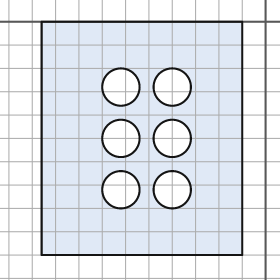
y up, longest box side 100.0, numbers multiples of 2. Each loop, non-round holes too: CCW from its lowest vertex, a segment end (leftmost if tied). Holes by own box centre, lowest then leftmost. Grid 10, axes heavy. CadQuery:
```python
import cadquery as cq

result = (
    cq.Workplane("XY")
    .moveTo(-96.0, -100.0)
    .lineTo(-10.0, -100.0)
    .lineTo(-10.0, 0.0)
    .lineTo(-96.0, 0.0)
    .close()
    .moveTo(-62.0, -72.0)
    .circle(8.0)
    .moveTo(-40.0, -72.0)
    .circle(8.0)
    .moveTo(-62.0, -50.0)
    .circle(8.0)
    .moveTo(-40.0, -50.0)
    .circle(8.0)
    .moveTo(-62.0, -28.0)
    .circle(8.0)
    .moveTo(-40.0, -28.0)
    .circle(8.0)
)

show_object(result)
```